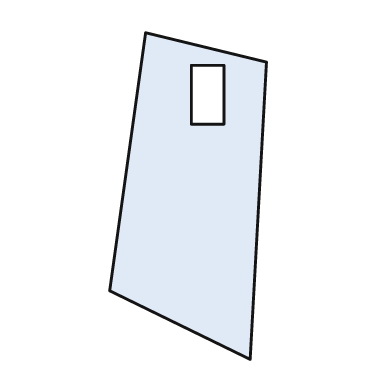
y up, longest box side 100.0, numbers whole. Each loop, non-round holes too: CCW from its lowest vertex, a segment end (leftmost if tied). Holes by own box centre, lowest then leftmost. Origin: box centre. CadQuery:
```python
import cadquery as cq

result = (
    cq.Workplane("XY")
    .moveTo(19.0, -50.0)
    .lineTo(24.0, 41.0)
    .lineTo(-13.0, 50.0)
    .lineTo(-24.0, -29.0)
    .close()
    .moveTo(1.0, 22.0)
    .lineTo(11.0, 22.0)
    .lineTo(11.0, 40.0)
    .lineTo(1.0, 40.0)
    .close()
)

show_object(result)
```